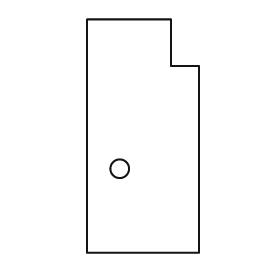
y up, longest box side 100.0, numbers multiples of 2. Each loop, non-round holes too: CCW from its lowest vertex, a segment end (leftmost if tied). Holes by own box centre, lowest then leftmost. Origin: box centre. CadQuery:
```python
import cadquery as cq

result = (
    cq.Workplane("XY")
    .moveTo(-24.0, -50.0)
    .lineTo(24.0, -50.0)
    .lineTo(24.0, 30.0)
    .lineTo(12.0, 30.0)
    .lineTo(12.0, 50.0)
    .lineTo(-24.0, 50.0)
    .close()
    .moveTo(-10.0, -14.0)
    .circle(4.0)
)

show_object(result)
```